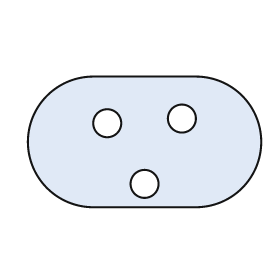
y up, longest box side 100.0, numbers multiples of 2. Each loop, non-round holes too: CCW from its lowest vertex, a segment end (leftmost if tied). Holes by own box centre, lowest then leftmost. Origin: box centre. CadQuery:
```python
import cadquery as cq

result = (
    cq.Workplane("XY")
    .moveTo(-22.0, -28.0)
    .lineTo(22.0, -28.0)
    .threePointArc((50.0, 0.0), (22.0, 28.0))
    .lineTo(-22.0, 28.0)
    .threePointArc((-50.0, 0.0), (-22.0, -28.0))
    .close()
    .moveTo(0.0, -18.0)
    .circle(6.0)
    .moveTo(-16.0, 8.0)
    .circle(6.0)
    .moveTo(16.0, 10.0)
    .circle(6.0)
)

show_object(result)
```